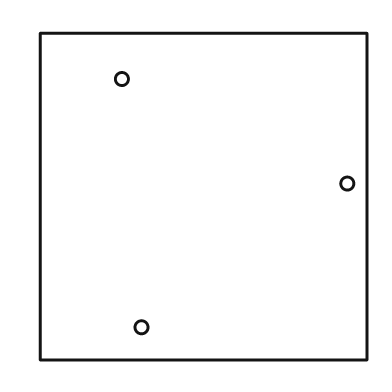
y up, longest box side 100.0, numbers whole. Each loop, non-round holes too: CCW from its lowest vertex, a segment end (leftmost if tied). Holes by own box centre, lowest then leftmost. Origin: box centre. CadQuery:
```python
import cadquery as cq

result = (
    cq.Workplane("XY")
    .moveTo(-50.0, -50.0)
    .lineTo(50.0, -50.0)
    .lineTo(50.0, 50.0)
    .lineTo(-50.0, 50.0)
    .close()
    .moveTo(-19.0, -40.0)
    .circle(2.0)
    .moveTo(44.0, 4.0)
    .circle(2.0)
    .moveTo(-25.0, 36.0)
    .circle(2.0)
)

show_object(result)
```